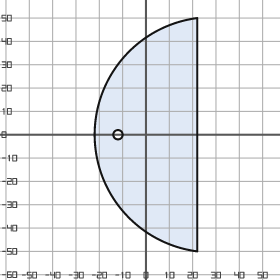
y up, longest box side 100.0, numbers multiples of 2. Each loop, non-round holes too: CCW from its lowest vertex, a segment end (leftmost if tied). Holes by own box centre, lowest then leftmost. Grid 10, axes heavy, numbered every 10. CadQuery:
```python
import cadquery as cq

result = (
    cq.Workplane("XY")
    .moveTo(22.0, -50.0)
    .lineTo(22.0, 50.0)
    .threePointArc((-22.0, 0.0), (22.0, -50.0))
    .close()
    .moveTo(-12.0, 0.0)
    .circle(2.0)
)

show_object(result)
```